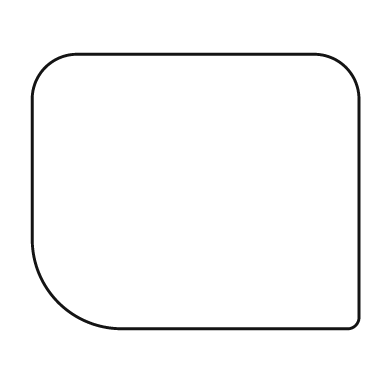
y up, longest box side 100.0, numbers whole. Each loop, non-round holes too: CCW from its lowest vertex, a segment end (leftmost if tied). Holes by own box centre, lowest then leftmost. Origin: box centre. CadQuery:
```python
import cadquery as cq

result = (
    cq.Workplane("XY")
    .moveTo(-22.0, -42.0)
    .lineTo(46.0, -42.0)
    .threePointArc((49.0, -41.0), (50.0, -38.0))
    .lineTo(50.0, 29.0)
    .threePointArc((46.0, 38.0), (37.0, 42.0))
    .lineTo(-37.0, 42.0)
    .threePointArc((-46.0, 38.0), (-50.0, 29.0))
    .lineTo(-50.0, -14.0)
    .threePointArc((-42.0, -34.0), (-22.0, -42.0))
    .close()
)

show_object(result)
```